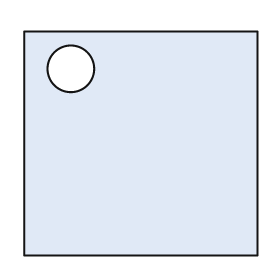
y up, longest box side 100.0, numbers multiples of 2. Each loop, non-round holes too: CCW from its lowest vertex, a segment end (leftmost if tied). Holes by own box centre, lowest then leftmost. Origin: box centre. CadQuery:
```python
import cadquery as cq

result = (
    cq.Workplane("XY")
    .moveTo(-50.0, -48.0)
    .lineTo(50.0, -48.0)
    .lineTo(50.0, 48.0)
    .lineTo(-50.0, 48.0)
    .close()
    .moveTo(-30.0, 32.0)
    .circle(10.0)
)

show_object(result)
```